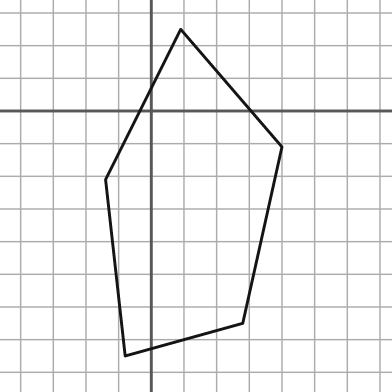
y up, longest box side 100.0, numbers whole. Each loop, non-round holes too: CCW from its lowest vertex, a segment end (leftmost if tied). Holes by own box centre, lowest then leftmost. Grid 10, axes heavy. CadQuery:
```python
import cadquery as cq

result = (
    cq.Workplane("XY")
    .moveTo(-8.0, -75.0)
    .lineTo(28.0, -65.0)
    .lineTo(40.0, -11.0)
    .lineTo(9.0, 25.0)
    .lineTo(-14.0, -21.0)
    .close()
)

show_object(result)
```